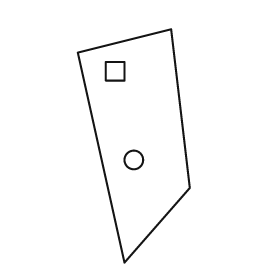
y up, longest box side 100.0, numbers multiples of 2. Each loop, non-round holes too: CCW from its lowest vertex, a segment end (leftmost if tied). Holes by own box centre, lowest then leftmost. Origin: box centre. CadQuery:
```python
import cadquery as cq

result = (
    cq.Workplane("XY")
    .moveTo(-4.0, -50.0)
    .lineTo(24.0, -18.0)
    .lineTo(16.0, 50.0)
    .lineTo(-24.0, 40.0)
    .close()
    .moveTo(0.0, -6.0)
    .circle(4.0)
    .moveTo(-12.0, 28.0)
    .lineTo(-4.0, 28.0)
    .lineTo(-4.0, 36.0)
    .lineTo(-12.0, 36.0)
    .close()
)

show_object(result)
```